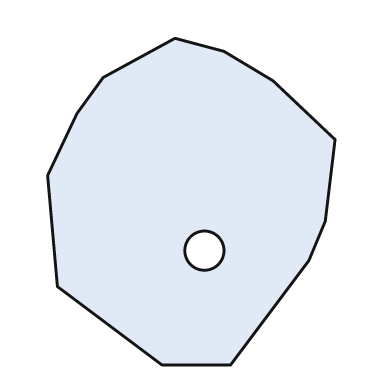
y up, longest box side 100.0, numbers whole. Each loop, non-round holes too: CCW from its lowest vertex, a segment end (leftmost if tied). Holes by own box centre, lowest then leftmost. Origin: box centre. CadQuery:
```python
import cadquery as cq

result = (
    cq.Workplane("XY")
    .moveTo(-9.0, -50.0)
    .lineTo(12.0, -50.0)
    .lineTo(36.0, -18.0)
    .lineTo(41.0, -6.0)
    .lineTo(44.0, 19.0)
    .lineTo(25.0, 37.0)
    .lineTo(10.0, 46.0)
    .lineTo(-5.0, 50.0)
    .lineTo(-27.0, 38.0)
    .lineTo(-35.0, 27.0)
    .lineTo(-44.0, 8.0)
    .lineTo(-41.0, -26.0)
    .close()
    .moveTo(4.0, -15.0)
    .circle(6.0)
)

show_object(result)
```